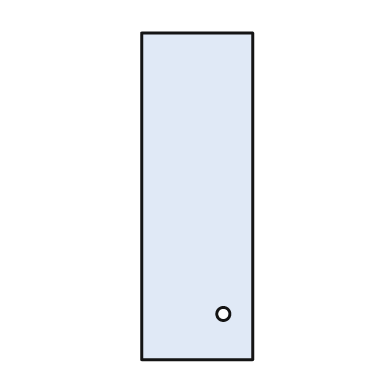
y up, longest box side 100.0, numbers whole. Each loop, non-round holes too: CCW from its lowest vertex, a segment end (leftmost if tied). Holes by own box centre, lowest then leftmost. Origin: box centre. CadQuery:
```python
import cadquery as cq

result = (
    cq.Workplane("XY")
    .moveTo(-17.0, -50.0)
    .lineTo(17.0, -50.0)
    .lineTo(17.0, 50.0)
    .lineTo(-17.0, 50.0)
    .close()
    .moveTo(8.0, -36.0)
    .circle(2.0)
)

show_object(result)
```